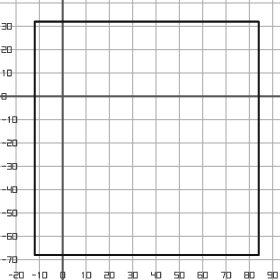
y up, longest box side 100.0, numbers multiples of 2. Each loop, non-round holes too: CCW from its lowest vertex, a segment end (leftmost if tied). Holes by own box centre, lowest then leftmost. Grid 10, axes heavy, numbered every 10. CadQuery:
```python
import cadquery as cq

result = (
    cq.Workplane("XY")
    .moveTo(-12.0, -68.0)
    .lineTo(84.0, -68.0)
    .lineTo(84.0, 32.0)
    .lineTo(-12.0, 32.0)
    .close()
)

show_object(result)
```